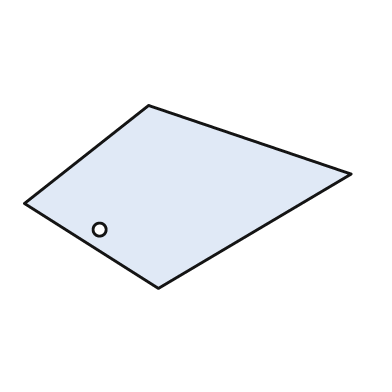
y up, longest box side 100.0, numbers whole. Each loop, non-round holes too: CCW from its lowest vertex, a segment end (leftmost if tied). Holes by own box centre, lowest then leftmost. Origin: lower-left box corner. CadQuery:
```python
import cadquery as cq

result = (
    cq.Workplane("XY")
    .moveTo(41.0, 0.0)
    .lineTo(100.0, 35.0)
    .lineTo(38.0, 56.0)
    .lineTo(0.0, 26.0)
    .close()
    .moveTo(23.0, 18.0)
    .circle(2.0)
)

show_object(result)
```